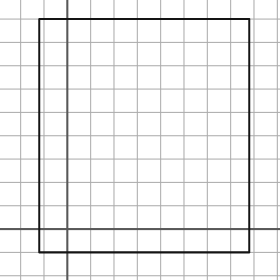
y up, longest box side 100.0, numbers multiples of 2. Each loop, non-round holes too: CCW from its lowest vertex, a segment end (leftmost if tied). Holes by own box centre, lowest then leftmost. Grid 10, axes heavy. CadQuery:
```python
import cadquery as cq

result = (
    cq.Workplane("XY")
    .moveTo(-12.0, -10.0)
    .lineTo(78.0, -10.0)
    .lineTo(78.0, 90.0)
    .lineTo(-12.0, 90.0)
    .close()
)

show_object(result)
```